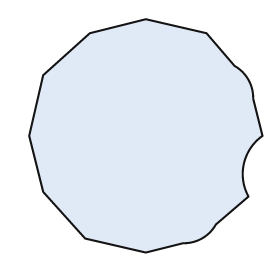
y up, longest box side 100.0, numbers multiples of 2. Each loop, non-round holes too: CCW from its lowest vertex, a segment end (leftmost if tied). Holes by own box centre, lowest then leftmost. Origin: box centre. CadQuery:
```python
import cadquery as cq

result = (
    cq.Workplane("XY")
    .moveTo(0.0, -50.0)
    .lineTo(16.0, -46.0)
    .threePointArc((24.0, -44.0), (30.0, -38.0))
    .lineTo(44.0, -26.0)
    .threePointArc((42.0, -12.0), (50.0, 0.0))
    .lineTo(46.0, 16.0)
    .threePointArc((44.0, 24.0), (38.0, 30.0))
    .lineTo(26.0, 44.0)
    .lineTo(0.0, 50.0)
    .lineTo(-24.0, 44.0)
    .lineTo(-44.0, 26.0)
    .lineTo(-50.0, 0.0)
    .lineTo(-44.0, -24.0)
    .lineTo(-26.0, -44.0)
    .close()
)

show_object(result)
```